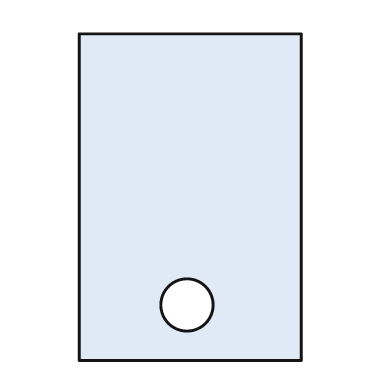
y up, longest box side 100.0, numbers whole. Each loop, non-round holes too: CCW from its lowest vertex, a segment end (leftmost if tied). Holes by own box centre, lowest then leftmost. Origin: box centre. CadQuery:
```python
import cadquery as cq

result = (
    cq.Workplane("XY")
    .moveTo(-34.0, -50.0)
    .lineTo(34.0, -50.0)
    .lineTo(34.0, 50.0)
    .lineTo(-34.0, 50.0)
    .close()
    .moveTo(-1.0, -33.0)
    .circle(8.0)
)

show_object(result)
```